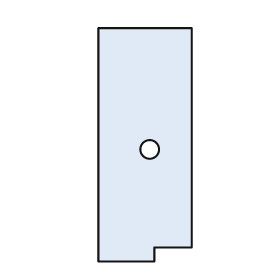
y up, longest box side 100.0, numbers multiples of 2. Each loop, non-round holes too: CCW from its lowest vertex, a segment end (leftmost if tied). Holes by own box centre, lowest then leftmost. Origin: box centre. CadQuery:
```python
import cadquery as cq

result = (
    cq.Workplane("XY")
    .moveTo(-20.0, -50.0)
    .lineTo(4.0, -50.0)
    .lineTo(4.0, -44.0)
    .lineTo(20.0, -44.0)
    .lineTo(20.0, 50.0)
    .lineTo(-20.0, 50.0)
    .close()
    .moveTo(2.0, -2.0)
    .circle(4.0)
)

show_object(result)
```